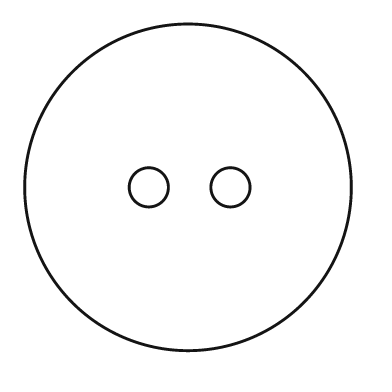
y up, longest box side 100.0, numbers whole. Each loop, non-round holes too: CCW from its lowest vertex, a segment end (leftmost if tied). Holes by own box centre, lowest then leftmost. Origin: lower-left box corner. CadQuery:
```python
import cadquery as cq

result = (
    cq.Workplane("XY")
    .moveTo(50.0, 50.0)
    .circle(50.0)
    .moveTo(38.0, 50.0)
    .circle(6.0)
    .moveTo(63.0, 50.0)
    .circle(6.0)
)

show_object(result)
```